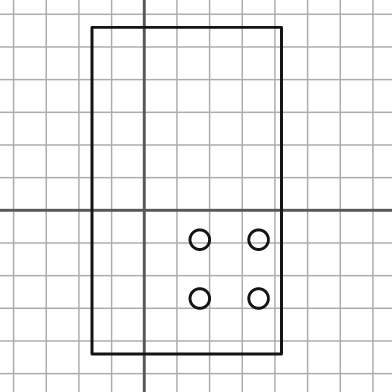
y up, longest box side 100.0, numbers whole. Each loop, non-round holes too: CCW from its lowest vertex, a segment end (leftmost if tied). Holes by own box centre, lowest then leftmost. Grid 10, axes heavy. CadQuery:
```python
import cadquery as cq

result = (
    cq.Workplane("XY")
    .moveTo(-16.0, -44.0)
    .lineTo(42.0, -44.0)
    .lineTo(42.0, 56.0)
    .lineTo(-16.0, 56.0)
    .close()
    .moveTo(17.0, -27.0)
    .circle(3.0)
    .moveTo(35.0, -27.0)
    .circle(3.0)
    .moveTo(17.0, -9.0)
    .circle(3.0)
    .moveTo(35.0, -9.0)
    .circle(3.0)
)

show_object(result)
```